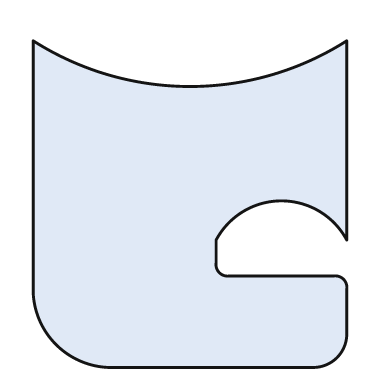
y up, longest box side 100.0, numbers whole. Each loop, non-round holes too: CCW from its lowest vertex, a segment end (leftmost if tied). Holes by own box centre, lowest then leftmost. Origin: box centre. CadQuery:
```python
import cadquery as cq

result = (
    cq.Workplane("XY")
    .moveTo(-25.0, -50.0)
    .lineTo(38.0, -50.0)
    .threePointArc((45.0, -47.0), (48.0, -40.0))
    .lineTo(48.0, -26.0)
    .threePointArc((47.0, -23.0), (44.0, -22.0))
    .lineTo(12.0, -22.0)
    .threePointArc((9.0, -21.0), (8.0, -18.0))
    .lineTo(8.0, -11.0)
    .threePointArc((28.0, 1.0), (48.0, -11.0))
    .lineTo(48.0, 50.0)
    .threePointArc((0.0, 36.0), (-48.0, 50.0))
    .lineTo(-48.0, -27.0)
    .threePointArc((-41.0, -43.0), (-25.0, -50.0))
    .close()
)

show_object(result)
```